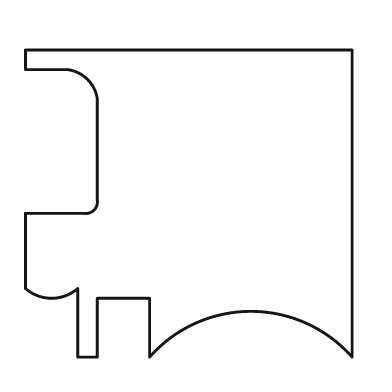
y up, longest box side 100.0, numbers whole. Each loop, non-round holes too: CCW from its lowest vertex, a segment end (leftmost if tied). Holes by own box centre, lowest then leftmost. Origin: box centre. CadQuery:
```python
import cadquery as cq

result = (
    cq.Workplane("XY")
    .moveTo(-34.0, -47.0)
    .lineTo(-28.0, -47.0)
    .lineTo(-28.0, -29.0)
    .lineTo(-12.0, -29.0)
    .lineTo(-12.0, -47.0)
    .threePointArc((19.0, -33.0), (50.0, -47.0))
    .lineTo(50.0, 47.0)
    .lineTo(-50.0, 47.0)
    .lineTo(-50.0, 41.0)
    .lineTo(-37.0, 41.0)
    .threePointArc((-31.0, 38.0), (-28.0, 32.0))
    .lineTo(-28.0, 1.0)
    .threePointArc((-29.0, -2.0), (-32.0, -3.0))
    .lineTo(-50.0, -3.0)
    .lineTo(-50.0, -26.0)
    .threePointArc((-42.0, -29.0), (-34.0, -26.0))
    .close()
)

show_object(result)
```